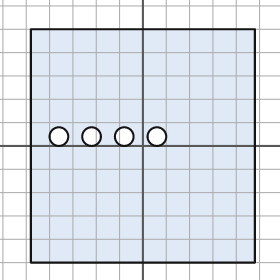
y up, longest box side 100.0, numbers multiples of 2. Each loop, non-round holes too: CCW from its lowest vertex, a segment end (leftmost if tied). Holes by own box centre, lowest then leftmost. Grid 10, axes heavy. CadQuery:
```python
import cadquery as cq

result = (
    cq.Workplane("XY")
    .moveTo(-48.0, -50.0)
    .lineTo(48.0, -50.0)
    .lineTo(48.0, 50.0)
    .lineTo(-48.0, 50.0)
    .close()
    .moveTo(-36.0, 4.0)
    .circle(4.0)
    .moveTo(-22.0, 4.0)
    .circle(4.0)
    .moveTo(-8.0, 4.0)
    .circle(4.0)
    .moveTo(6.0, 4.0)
    .circle(4.0)
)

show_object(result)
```